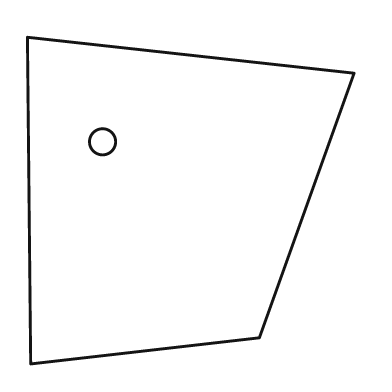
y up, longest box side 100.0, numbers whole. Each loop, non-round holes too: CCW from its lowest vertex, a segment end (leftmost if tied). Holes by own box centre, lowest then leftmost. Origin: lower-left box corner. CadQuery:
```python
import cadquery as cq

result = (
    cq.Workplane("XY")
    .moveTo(1.0, 0.0)
    .lineTo(71.0, 8.0)
    .lineTo(100.0, 89.0)
    .lineTo(0.0, 100.0)
    .close()
    .moveTo(23.0, 68.0)
    .circle(4.0)
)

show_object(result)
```